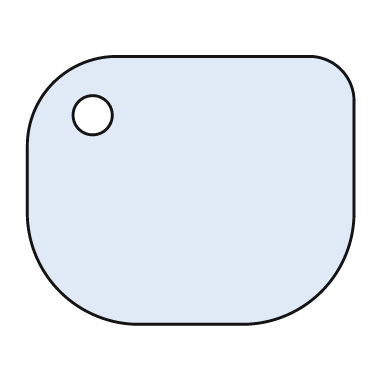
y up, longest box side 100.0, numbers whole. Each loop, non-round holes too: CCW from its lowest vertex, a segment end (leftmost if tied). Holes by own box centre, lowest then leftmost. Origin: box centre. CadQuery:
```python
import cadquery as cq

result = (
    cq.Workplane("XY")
    .moveTo(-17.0, -41.0)
    .lineTo(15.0, -41.0)
    .threePointArc((40.0, -31.0), (50.0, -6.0))
    .lineTo(50.0, 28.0)
    .threePointArc((46.0, 37.0), (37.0, 41.0))
    .lineTo(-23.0, 41.0)
    .threePointArc((-42.0, 33.0), (-50.0, 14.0))
    .lineTo(-50.0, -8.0)
    .threePointArc((-40.0, -31.0), (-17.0, -41.0))
    .close()
    .moveTo(-30.0, 23.0)
    .circle(6.0)
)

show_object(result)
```